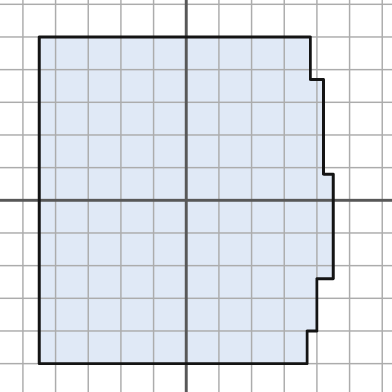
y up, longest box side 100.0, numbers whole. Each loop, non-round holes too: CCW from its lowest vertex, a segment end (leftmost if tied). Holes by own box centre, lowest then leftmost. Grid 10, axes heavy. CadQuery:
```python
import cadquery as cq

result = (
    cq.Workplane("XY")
    .moveTo(-45.0, -50.0)
    .lineTo(37.0, -50.0)
    .lineTo(37.0, -40.0)
    .lineTo(40.0, -40.0)
    .lineTo(40.0, -24.0)
    .lineTo(45.0, -24.0)
    .lineTo(45.0, 8.0)
    .lineTo(42.0, 8.0)
    .lineTo(42.0, 37.0)
    .lineTo(38.0, 37.0)
    .lineTo(38.0, 50.0)
    .lineTo(-45.0, 50.0)
    .close()
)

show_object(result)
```